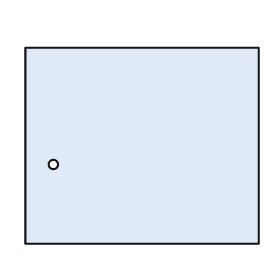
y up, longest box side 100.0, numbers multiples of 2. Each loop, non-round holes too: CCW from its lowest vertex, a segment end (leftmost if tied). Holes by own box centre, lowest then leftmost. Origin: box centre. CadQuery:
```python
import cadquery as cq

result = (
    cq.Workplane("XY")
    .moveTo(-50.0, -42.0)
    .lineTo(50.0, -42.0)
    .lineTo(50.0, 42.0)
    .lineTo(-50.0, 42.0)
    .close()
    .moveTo(-38.0, -8.0)
    .circle(2.0)
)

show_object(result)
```